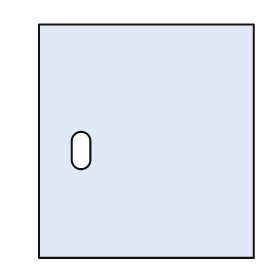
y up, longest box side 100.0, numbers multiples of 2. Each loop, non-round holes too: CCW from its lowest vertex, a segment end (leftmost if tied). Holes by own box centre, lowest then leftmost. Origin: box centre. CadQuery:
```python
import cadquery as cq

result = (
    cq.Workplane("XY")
    .moveTo(-46.0, -50.0)
    .lineTo(46.0, -50.0)
    .lineTo(46.0, 50.0)
    .lineTo(-46.0, 50.0)
    .close()
    .moveTo(-32.0, -8.0)
    .threePointArc((-28.0, -12.0), (-24.0, -8.0))
    .lineTo(-24.0, 0.0)
    .threePointArc((-28.0, 4.0), (-32.0, 0.0))
    .close()
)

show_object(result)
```